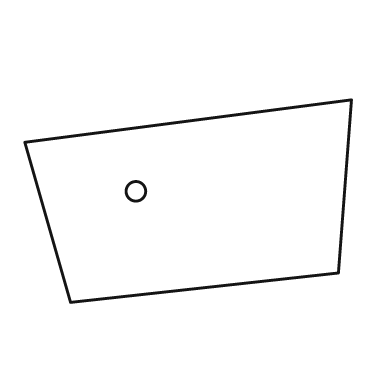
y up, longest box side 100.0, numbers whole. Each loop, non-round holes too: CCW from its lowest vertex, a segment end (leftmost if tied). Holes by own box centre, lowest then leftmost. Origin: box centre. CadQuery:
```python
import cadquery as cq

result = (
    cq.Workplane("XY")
    .moveTo(-36.0, -31.0)
    .lineTo(46.0, -22.0)
    .lineTo(50.0, 31.0)
    .lineTo(-50.0, 18.0)
    .close()
    .moveTo(-16.0, 3.0)
    .circle(3.0)
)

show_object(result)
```